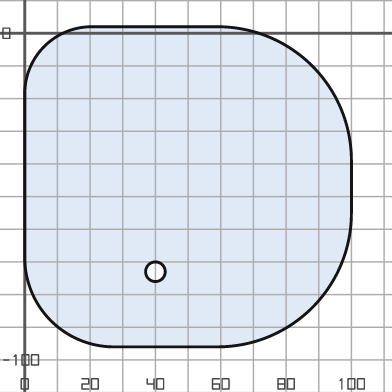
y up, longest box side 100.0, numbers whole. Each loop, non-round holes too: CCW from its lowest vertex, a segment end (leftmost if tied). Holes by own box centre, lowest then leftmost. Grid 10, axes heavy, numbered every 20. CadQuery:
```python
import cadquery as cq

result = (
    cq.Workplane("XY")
    .moveTo(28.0, -96.0)
    .lineTo(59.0, -96.0)
    .threePointArc((88.0, -84.0), (100.0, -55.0))
    .lineTo(100.0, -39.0)
    .threePointArc((88.0, -10.0), (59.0, 2.0))
    .lineTo(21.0, 2.0)
    .threePointArc((6.0, -4.0), (0.0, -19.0))
    .lineTo(0.0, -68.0)
    .threePointArc((8.0, -88.0), (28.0, -96.0))
    .close()
    .moveTo(40.0, -73.0)
    .circle(3.0)
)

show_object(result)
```